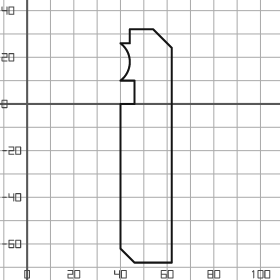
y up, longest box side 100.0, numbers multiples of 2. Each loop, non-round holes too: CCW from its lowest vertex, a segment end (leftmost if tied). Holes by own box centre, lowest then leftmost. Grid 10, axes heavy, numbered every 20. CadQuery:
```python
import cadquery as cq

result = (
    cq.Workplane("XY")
    .moveTo(46.0, -68.0)
    .lineTo(62.0, -68.0)
    .lineTo(62.0, 24.0)
    .lineTo(54.0, 32.0)
    .lineTo(44.0, 32.0)
    .lineTo(44.0, 26.0)
    .lineTo(40.0, 26.0)
    .threePointArc((44.0, 18.0), (40.0, 10.0))
    .lineTo(46.0, 10.0)
    .lineTo(46.0, 0.0)
    .lineTo(40.0, 0.0)
    .lineTo(40.0, -62.0)
    .close()
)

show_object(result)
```